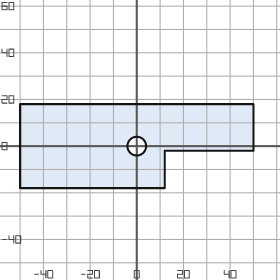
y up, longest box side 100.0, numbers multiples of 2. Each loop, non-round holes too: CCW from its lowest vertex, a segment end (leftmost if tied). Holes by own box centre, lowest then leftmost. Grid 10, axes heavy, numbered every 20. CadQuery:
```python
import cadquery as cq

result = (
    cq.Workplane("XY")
    .moveTo(-50.0, -18.0)
    .lineTo(12.0, -18.0)
    .lineTo(12.0, -2.0)
    .lineTo(50.0, -2.0)
    .lineTo(50.0, 18.0)
    .lineTo(-50.0, 18.0)
    .close()
    .moveTo(0.0, 0.0)
    .circle(4.0)
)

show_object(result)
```